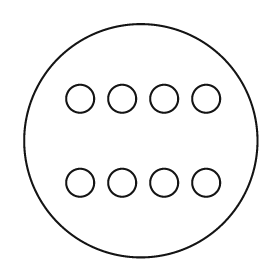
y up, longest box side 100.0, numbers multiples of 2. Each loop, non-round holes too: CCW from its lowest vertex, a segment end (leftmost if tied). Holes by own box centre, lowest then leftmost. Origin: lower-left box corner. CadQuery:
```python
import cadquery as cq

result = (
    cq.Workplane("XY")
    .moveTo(50.0, 50.0)
    .circle(50.0)
    .moveTo(24.0, 32.0)
    .circle(6.0)
    .moveTo(42.0, 32.0)
    .circle(6.0)
    .moveTo(60.0, 32.0)
    .circle(6.0)
    .moveTo(78.0, 32.0)
    .circle(6.0)
    .moveTo(24.0, 68.0)
    .circle(6.0)
    .moveTo(42.0, 68.0)
    .circle(6.0)
    .moveTo(60.0, 68.0)
    .circle(6.0)
    .moveTo(78.0, 68.0)
    .circle(6.0)
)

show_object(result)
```